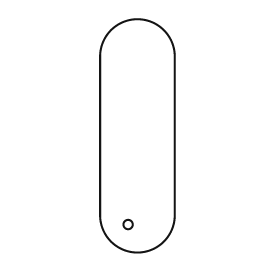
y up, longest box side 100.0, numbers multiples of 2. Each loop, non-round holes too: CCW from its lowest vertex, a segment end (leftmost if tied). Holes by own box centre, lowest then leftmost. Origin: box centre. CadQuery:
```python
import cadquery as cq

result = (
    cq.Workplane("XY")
    .moveTo(-16.0, -34.0)
    .threePointArc((0.0, -50.0), (16.0, -34.0))
    .lineTo(16.0, 34.0)
    .threePointArc((0.0, 50.0), (-16.0, 34.0))
    .close()
    .moveTo(-4.0, -38.0)
    .circle(2.0)
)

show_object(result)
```